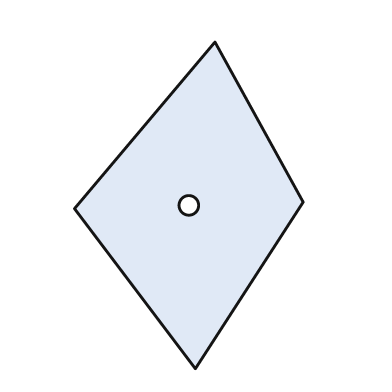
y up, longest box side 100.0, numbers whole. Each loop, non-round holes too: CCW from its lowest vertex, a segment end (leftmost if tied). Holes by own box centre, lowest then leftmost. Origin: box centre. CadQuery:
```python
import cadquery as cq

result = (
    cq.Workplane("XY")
    .moveTo(2.0, -50.0)
    .lineTo(35.0, 1.0)
    .lineTo(8.0, 50.0)
    .lineTo(-35.0, -1.0)
    .close()
    .moveTo(0.0, 0.0)
    .circle(3.0)
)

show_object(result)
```